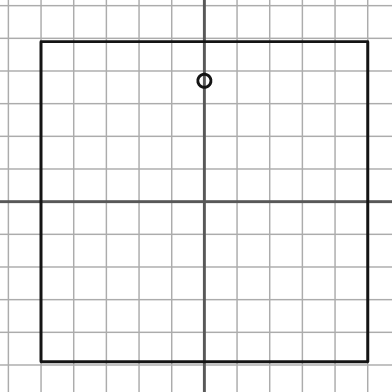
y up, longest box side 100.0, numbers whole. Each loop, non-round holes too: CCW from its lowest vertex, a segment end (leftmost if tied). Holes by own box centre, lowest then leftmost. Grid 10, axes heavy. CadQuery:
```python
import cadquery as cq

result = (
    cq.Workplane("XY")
    .moveTo(-50.0, -49.0)
    .lineTo(50.0, -49.0)
    .lineTo(50.0, 49.0)
    .lineTo(-50.0, 49.0)
    .close()
    .moveTo(0.0, 37.0)
    .circle(2.0)
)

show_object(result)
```